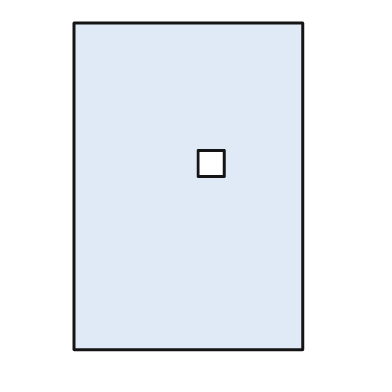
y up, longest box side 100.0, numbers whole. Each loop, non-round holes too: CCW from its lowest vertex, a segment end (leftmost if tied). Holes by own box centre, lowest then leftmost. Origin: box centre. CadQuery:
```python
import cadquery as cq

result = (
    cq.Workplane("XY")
    .moveTo(-35.0, -50.0)
    .lineTo(35.0, -50.0)
    .lineTo(35.0, 50.0)
    .lineTo(-35.0, 50.0)
    .close()
    .moveTo(3.0, 3.0)
    .lineTo(11.0, 3.0)
    .lineTo(11.0, 11.0)
    .lineTo(3.0, 11.0)
    .close()
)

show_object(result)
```